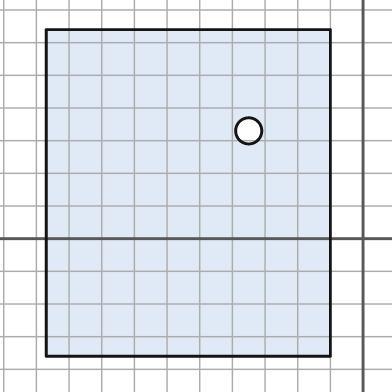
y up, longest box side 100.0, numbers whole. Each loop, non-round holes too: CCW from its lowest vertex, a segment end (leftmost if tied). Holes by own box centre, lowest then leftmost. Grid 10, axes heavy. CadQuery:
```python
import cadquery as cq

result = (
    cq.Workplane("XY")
    .moveTo(-97.0, -36.0)
    .lineTo(-10.0, -36.0)
    .lineTo(-10.0, 64.0)
    .lineTo(-97.0, 64.0)
    .close()
    .moveTo(-35.0, 33.0)
    .circle(4.0)
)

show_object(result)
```